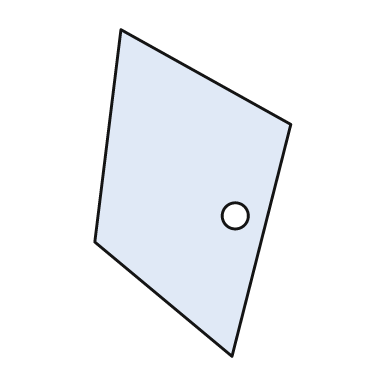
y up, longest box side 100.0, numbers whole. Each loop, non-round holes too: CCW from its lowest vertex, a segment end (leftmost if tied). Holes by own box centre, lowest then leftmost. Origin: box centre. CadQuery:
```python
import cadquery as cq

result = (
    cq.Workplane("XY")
    .moveTo(12.0, -50.0)
    .lineTo(30.0, 21.0)
    .lineTo(-22.0, 50.0)
    .lineTo(-30.0, -15.0)
    .close()
    .moveTo(13.0, -7.0)
    .circle(4.0)
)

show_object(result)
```